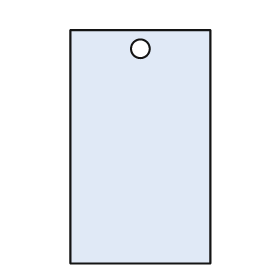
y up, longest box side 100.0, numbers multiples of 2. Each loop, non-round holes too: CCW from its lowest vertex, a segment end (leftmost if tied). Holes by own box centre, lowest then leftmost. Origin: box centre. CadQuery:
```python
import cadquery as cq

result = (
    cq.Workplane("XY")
    .moveTo(-30.0, -50.0)
    .lineTo(30.0, -50.0)
    .lineTo(30.0, 50.0)
    .lineTo(-30.0, 50.0)
    .close()
    .moveTo(0.0, 42.0)
    .circle(4.0)
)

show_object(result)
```